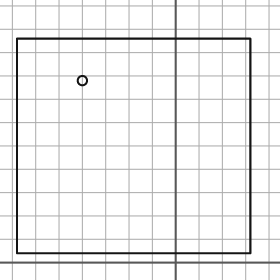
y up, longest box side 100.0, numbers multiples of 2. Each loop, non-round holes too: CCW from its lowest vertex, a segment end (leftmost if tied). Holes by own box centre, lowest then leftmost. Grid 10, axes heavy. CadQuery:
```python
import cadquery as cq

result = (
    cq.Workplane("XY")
    .moveTo(-68.0, 4.0)
    .lineTo(32.0, 4.0)
    .lineTo(32.0, 96.0)
    .lineTo(-68.0, 96.0)
    .close()
    .moveTo(-40.0, 78.0)
    .circle(2.0)
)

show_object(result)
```